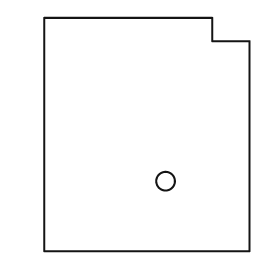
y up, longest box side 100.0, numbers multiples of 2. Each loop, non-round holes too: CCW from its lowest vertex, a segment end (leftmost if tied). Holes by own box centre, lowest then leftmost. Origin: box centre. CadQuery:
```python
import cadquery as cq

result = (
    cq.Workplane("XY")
    .moveTo(-44.0, -50.0)
    .lineTo(44.0, -50.0)
    .lineTo(44.0, 40.0)
    .lineTo(28.0, 40.0)
    .lineTo(28.0, 50.0)
    .lineTo(-44.0, 50.0)
    .close()
    .moveTo(8.0, -20.0)
    .circle(4.0)
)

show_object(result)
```